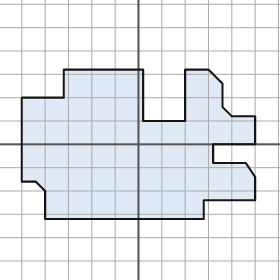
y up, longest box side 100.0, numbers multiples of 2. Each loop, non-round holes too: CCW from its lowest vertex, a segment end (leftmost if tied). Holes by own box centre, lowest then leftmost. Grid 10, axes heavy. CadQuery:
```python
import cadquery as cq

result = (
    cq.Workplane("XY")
    .moveTo(-40.0, -32.0)
    .lineTo(28.0, -32.0)
    .lineTo(28.0, -24.0)
    .lineTo(50.0, -24.0)
    .lineTo(50.0, -14.0)
    .lineTo(46.0, -8.0)
    .lineTo(32.0, -8.0)
    .lineTo(32.0, 0.0)
    .lineTo(50.0, 0.0)
    .lineTo(50.0, 12.0)
    .lineTo(40.0, 12.0)
    .lineTo(36.0, 16.0)
    .lineTo(36.0, 26.0)
    .lineTo(30.0, 32.0)
    .lineTo(20.0, 32.0)
    .lineTo(20.0, 10.0)
    .lineTo(2.0, 10.0)
    .lineTo(2.0, 32.0)
    .lineTo(-32.0, 32.0)
    .lineTo(-32.0, 20.0)
    .lineTo(-50.0, 20.0)
    .lineTo(-50.0, -16.0)
    .lineTo(-44.0, -16.0)
    .lineTo(-40.0, -20.0)
    .close()
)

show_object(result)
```